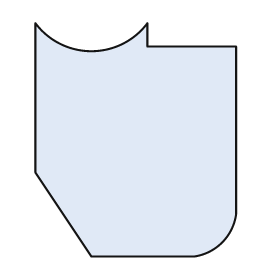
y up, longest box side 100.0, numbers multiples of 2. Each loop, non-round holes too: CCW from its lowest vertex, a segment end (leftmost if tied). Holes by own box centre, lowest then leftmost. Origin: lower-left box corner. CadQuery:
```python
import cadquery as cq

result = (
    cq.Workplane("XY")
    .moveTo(24.0, 0.0)
    .lineTo(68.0, 0.0)
    .threePointArc((80.0, 6.0), (86.0, 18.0))
    .lineTo(86.0, 90.0)
    .lineTo(48.0, 90.0)
    .lineTo(48.0, 100.0)
    .threePointArc((24.0, 88.0), (0.0, 100.0))
    .lineTo(0.0, 36.0)
    .close()
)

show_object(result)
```